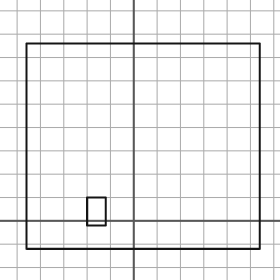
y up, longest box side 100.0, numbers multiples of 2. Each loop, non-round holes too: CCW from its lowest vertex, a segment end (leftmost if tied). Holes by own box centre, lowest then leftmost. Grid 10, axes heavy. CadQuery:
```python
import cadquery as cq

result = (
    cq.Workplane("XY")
    .moveTo(-46.0, -12.0)
    .lineTo(54.0, -12.0)
    .lineTo(54.0, 76.0)
    .lineTo(-46.0, 76.0)
    .close()
    .moveTo(-20.0, -2.0)
    .lineTo(-12.0, -2.0)
    .lineTo(-12.0, 10.0)
    .lineTo(-20.0, 10.0)
    .close()
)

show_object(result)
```